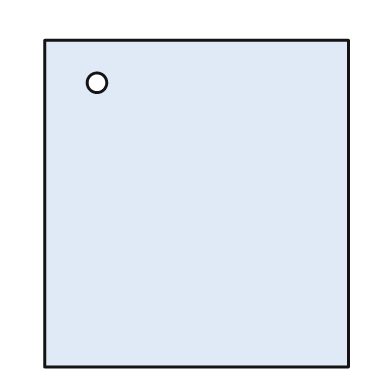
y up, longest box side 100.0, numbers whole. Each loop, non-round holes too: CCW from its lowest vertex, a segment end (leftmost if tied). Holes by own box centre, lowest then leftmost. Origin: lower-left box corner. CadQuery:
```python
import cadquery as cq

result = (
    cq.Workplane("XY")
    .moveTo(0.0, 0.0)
    .lineTo(93.0, 0.0)
    .lineTo(93.0, 100.0)
    .lineTo(0.0, 100.0)
    .close()
    .moveTo(16.0, 87.0)
    .circle(3.0)
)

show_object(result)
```